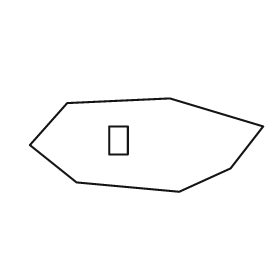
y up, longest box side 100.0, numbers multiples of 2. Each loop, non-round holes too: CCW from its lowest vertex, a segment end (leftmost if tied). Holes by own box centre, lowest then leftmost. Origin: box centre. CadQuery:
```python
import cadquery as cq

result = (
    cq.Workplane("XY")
    .moveTo(14.0, -20.0)
    .lineTo(36.0, -10.0)
    .lineTo(50.0, 8.0)
    .lineTo(10.0, 20.0)
    .lineTo(-34.0, 18.0)
    .lineTo(-50.0, 0.0)
    .lineTo(-30.0, -16.0)
    .close()
    .moveTo(-16.0, -4.0)
    .lineTo(-8.0, -4.0)
    .lineTo(-8.0, 8.0)
    .lineTo(-16.0, 8.0)
    .close()
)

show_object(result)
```